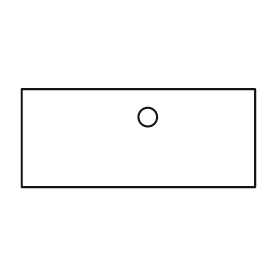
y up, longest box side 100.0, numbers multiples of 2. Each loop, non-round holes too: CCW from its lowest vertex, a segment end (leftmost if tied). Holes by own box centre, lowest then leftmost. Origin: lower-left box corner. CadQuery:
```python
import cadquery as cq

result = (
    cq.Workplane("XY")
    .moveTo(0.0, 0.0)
    .lineTo(100.0, 0.0)
    .lineTo(100.0, 42.0)
    .lineTo(0.0, 42.0)
    .close()
    .moveTo(54.0, 30.0)
    .circle(4.0)
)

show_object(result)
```